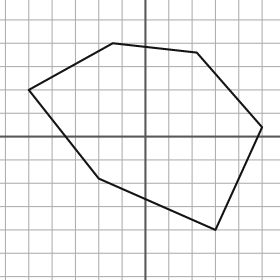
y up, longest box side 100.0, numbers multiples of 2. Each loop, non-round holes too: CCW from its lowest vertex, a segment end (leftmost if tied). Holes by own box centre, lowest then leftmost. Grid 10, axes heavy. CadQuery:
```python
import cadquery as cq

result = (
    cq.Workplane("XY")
    .moveTo(30.0, -40.0)
    .lineTo(50.0, 4.0)
    .lineTo(22.0, 36.0)
    .lineTo(-14.0, 40.0)
    .lineTo(-50.0, 20.0)
    .lineTo(-20.0, -18.0)
    .close()
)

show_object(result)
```